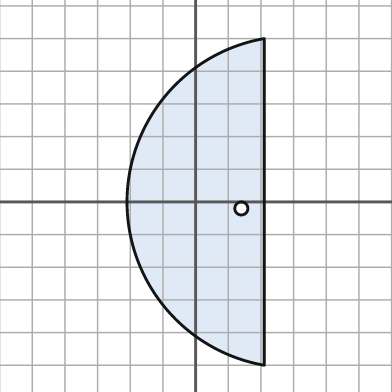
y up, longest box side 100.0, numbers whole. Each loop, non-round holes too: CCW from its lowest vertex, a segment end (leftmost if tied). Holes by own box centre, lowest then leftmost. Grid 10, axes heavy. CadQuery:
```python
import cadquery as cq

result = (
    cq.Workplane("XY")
    .moveTo(21.0, -50.0)
    .lineTo(21.0, 50.0)
    .threePointArc((-21.0, 0.0), (21.0, -50.0))
    .close()
    .moveTo(14.0, -2.0)
    .circle(2.0)
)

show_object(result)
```